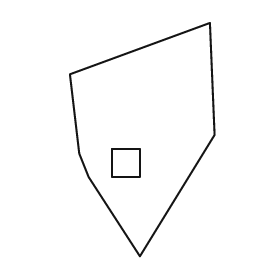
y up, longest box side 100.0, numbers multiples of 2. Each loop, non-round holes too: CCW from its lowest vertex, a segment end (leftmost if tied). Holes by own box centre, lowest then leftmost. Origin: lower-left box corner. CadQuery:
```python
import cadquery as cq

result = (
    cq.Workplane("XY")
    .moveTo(30.0, 0.0)
    .lineTo(62.0, 52.0)
    .lineTo(60.0, 100.0)
    .lineTo(0.0, 78.0)
    .lineTo(4.0, 44.0)
    .lineTo(8.0, 34.0)
    .close()
    .moveTo(18.0, 34.0)
    .lineTo(30.0, 34.0)
    .lineTo(30.0, 46.0)
    .lineTo(18.0, 46.0)
    .close()
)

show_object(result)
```